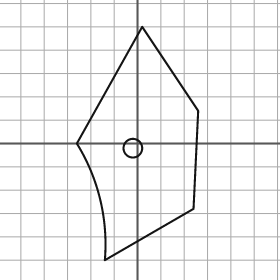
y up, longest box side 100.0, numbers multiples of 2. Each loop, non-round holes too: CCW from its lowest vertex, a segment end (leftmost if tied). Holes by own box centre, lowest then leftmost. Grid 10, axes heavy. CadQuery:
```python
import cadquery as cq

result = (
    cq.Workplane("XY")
    .moveTo(-14.0, -50.0)
    .lineTo(24.0, -28.0)
    .lineTo(26.0, 14.0)
    .lineTo(2.0, 50.0)
    .lineTo(-26.0, 0.0)
    .threePointArc((-16.0, -24.0), (-14.0, -50.0))
    .close()
    .moveTo(-2.0, -2.0)
    .circle(4.0)
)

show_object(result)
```